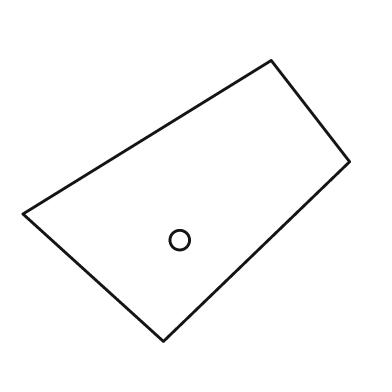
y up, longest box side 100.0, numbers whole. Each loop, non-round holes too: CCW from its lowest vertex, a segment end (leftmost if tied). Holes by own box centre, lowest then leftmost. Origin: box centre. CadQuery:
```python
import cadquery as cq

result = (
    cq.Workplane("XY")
    .moveTo(-7.0, -43.0)
    .lineTo(50.0, 12.0)
    .lineTo(26.0, 43.0)
    .lineTo(-50.0, -4.0)
    .close()
    .moveTo(-2.0, -12.0)
    .circle(3.0)
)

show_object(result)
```